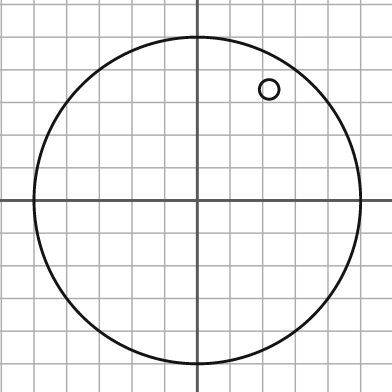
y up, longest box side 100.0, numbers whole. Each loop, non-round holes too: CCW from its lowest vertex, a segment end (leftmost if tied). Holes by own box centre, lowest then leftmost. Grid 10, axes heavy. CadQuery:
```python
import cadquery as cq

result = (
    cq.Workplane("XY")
    .moveTo(0.0, 0.0)
    .circle(50.0)
    .moveTo(22.0, 34.0)
    .circle(3.0)
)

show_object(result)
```